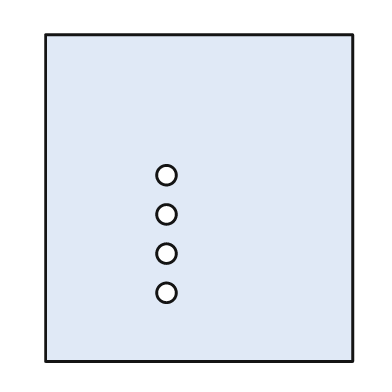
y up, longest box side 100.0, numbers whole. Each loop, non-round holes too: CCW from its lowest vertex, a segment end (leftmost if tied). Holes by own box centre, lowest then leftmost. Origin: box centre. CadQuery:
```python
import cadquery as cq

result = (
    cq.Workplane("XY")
    .moveTo(-47.0, -50.0)
    .lineTo(47.0, -50.0)
    .lineTo(47.0, 50.0)
    .lineTo(-47.0, 50.0)
    .close()
    .moveTo(-10.0, -29.0)
    .circle(3.0)
    .moveTo(-10.0, -17.0)
    .circle(3.0)
    .moveTo(-10.0, -5.0)
    .circle(3.0)
    .moveTo(-10.0, 7.0)
    .circle(3.0)
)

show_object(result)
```